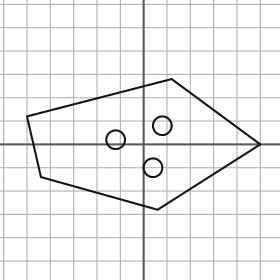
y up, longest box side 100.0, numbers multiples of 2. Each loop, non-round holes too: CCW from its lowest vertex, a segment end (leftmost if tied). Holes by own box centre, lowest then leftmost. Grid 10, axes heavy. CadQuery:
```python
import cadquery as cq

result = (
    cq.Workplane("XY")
    .moveTo(6.0, -28.0)
    .lineTo(50.0, 0.0)
    .lineTo(12.0, 28.0)
    .lineTo(-50.0, 12.0)
    .lineTo(-44.0, -14.0)
    .close()
    .moveTo(4.0, -10.0)
    .circle(4.0)
    .moveTo(-12.0, 2.0)
    .circle(4.0)
    .moveTo(8.0, 8.0)
    .circle(4.0)
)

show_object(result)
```